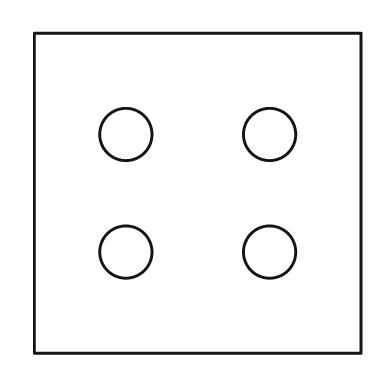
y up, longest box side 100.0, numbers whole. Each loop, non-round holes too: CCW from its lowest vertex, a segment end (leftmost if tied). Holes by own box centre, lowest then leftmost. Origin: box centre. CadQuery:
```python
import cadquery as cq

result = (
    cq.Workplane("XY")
    .moveTo(-50.0, -49.0)
    .lineTo(50.0, -49.0)
    .lineTo(50.0, 49.0)
    .lineTo(-50.0, 49.0)
    .close()
    .moveTo(-22.0, -18.0)
    .circle(8.0)
    .moveTo(22.0, -18.0)
    .circle(8.0)
    .moveTo(-22.0, 18.0)
    .circle(8.0)
    .moveTo(22.0, 18.0)
    .circle(8.0)
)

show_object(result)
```